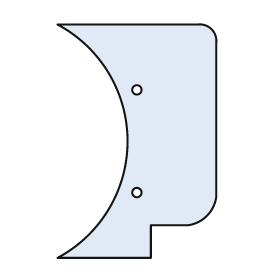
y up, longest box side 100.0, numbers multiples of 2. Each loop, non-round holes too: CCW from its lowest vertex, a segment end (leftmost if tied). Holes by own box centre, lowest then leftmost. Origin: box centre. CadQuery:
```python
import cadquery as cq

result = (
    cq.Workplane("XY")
    .moveTo(-34.0, -50.0)
    .lineTo(6.0, -50.0)
    .lineTo(6.0, -36.0)
    .lineTo(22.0, -36.0)
    .threePointArc((30.0, -32.0), (34.0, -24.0))
    .lineTo(34.0, 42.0)
    .threePointArc((32.0, 48.0), (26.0, 50.0))
    .lineTo(-34.0, 50.0)
    .threePointArc((-4.0, 0.0), (-34.0, -50.0))
    .close()
    .moveTo(0.0, -22.0)
    .circle(2.0)
    .moveTo(0.0, 22.0)
    .circle(2.0)
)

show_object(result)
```